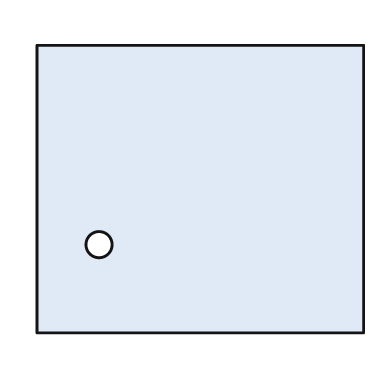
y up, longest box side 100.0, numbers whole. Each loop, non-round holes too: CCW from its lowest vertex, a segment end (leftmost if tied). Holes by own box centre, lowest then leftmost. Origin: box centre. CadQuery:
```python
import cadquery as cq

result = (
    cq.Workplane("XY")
    .moveTo(-50.0, -44.0)
    .lineTo(50.0, -44.0)
    .lineTo(50.0, 44.0)
    .lineTo(-50.0, 44.0)
    .close()
    .moveTo(-31.0, -17.0)
    .circle(4.0)
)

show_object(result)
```